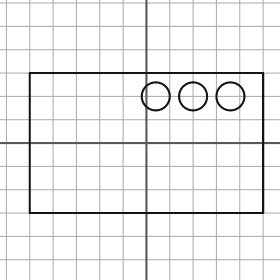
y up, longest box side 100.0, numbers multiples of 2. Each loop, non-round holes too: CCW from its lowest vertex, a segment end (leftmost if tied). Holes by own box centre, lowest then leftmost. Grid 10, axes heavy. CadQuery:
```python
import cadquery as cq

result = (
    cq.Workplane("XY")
    .moveTo(-50.0, -30.0)
    .lineTo(50.0, -30.0)
    .lineTo(50.0, 30.0)
    .lineTo(-50.0, 30.0)
    .close()
    .moveTo(4.0, 20.0)
    .circle(6.0)
    .moveTo(20.0, 20.0)
    .circle(6.0)
    .moveTo(36.0, 20.0)
    .circle(6.0)
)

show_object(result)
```